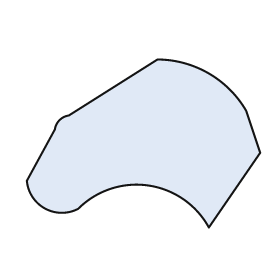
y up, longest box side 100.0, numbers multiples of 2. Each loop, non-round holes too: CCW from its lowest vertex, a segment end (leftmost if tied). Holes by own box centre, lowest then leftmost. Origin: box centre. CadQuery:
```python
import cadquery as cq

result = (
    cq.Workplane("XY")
    .moveTo(28.0, -36.0)
    .lineTo(50.0, -4.0)
    .lineTo(44.0, 14.0)
    .threePointArc((28.0, 30.0), (6.0, 36.0))
    .lineTo(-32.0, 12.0)
    .threePointArc((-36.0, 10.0), (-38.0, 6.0))
    .lineTo(-50.0, -16.0)
    .threePointArc((-42.0, -28.0), (-28.0, -28.0))
    .threePointArc((2.0, -18.0), (28.0, -36.0))
    .close()
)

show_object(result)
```